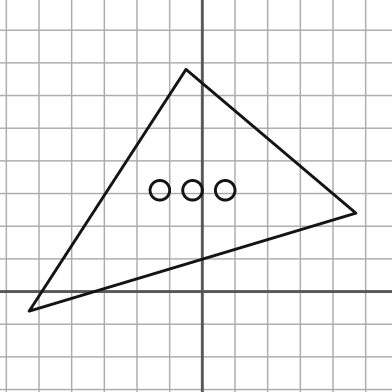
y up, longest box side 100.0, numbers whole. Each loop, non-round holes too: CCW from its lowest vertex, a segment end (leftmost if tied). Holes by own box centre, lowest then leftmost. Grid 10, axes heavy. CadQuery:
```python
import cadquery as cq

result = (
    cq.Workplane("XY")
    .moveTo(-53.0, -6.0)
    .lineTo(47.0, 24.0)
    .lineTo(-5.0, 68.0)
    .close()
    .moveTo(-13.0, 31.0)
    .circle(3.0)
    .moveTo(-3.0, 31.0)
    .circle(3.0)
    .moveTo(7.0, 31.0)
    .circle(3.0)
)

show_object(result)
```